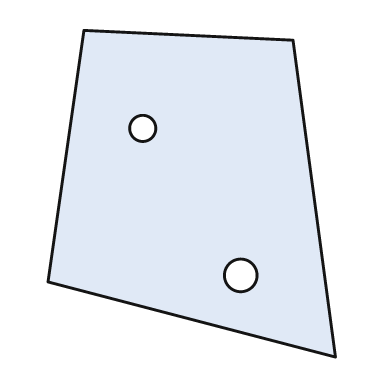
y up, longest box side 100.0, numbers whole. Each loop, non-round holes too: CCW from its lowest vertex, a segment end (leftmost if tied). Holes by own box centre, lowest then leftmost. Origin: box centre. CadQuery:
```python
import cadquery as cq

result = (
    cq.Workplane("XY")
    .moveTo(44.0, -50.0)
    .lineTo(31.0, 47.0)
    .lineTo(-33.0, 50.0)
    .lineTo(-44.0, -27.0)
    .close()
    .moveTo(15.0, -25.0)
    .circle(5.0)
    .moveTo(-15.0, 20.0)
    .circle(4.0)
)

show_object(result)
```